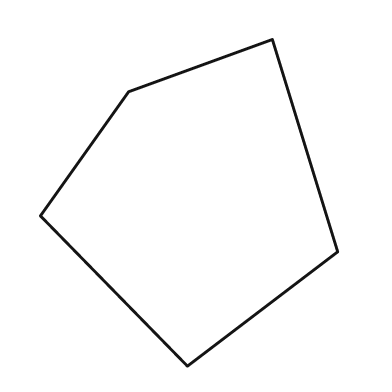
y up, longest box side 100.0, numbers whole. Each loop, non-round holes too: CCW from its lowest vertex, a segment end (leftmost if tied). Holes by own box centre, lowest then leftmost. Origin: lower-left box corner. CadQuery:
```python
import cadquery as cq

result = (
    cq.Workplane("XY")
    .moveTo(45.0, 0.0)
    .lineTo(91.0, 35.0)
    .lineTo(71.0, 100.0)
    .lineTo(27.0, 84.0)
    .lineTo(0.0, 46.0)
    .close()
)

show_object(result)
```